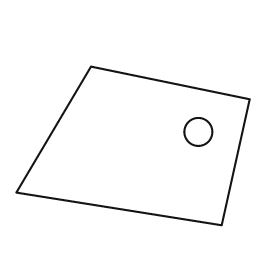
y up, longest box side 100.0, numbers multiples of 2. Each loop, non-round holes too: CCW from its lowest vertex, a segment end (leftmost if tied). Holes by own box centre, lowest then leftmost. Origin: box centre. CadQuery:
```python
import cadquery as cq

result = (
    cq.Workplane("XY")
    .moveTo(38.0, -34.0)
    .lineTo(50.0, 20.0)
    .lineTo(-18.0, 34.0)
    .lineTo(-50.0, -20.0)
    .close()
    .moveTo(28.0, 6.0)
    .circle(6.0)
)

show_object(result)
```